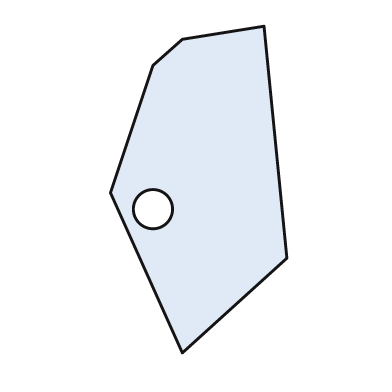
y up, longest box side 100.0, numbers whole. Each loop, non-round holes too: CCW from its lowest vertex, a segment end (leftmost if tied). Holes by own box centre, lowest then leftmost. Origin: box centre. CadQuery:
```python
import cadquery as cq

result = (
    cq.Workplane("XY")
    .moveTo(-5.0, -50.0)
    .lineTo(27.0, -21.0)
    .lineTo(20.0, 50.0)
    .lineTo(-5.0, 46.0)
    .lineTo(-14.0, 38.0)
    .lineTo(-27.0, -1.0)
    .close()
    .moveTo(-14.0, -6.0)
    .circle(6.0)
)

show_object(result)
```